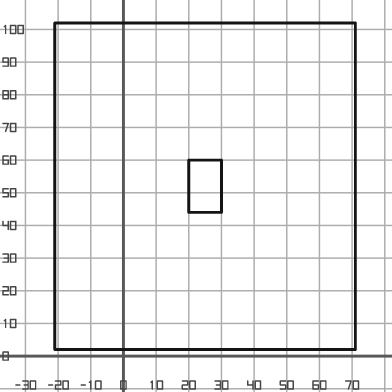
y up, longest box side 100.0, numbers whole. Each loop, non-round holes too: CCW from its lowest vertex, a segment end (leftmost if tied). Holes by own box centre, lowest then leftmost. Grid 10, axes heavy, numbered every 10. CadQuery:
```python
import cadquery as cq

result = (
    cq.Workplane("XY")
    .moveTo(-21.0, 2.0)
    .lineTo(71.0, 2.0)
    .lineTo(71.0, 102.0)
    .lineTo(-21.0, 102.0)
    .close()
    .moveTo(20.0, 44.0)
    .lineTo(30.0, 44.0)
    .lineTo(30.0, 60.0)
    .lineTo(20.0, 60.0)
    .close()
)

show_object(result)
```